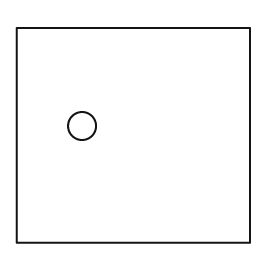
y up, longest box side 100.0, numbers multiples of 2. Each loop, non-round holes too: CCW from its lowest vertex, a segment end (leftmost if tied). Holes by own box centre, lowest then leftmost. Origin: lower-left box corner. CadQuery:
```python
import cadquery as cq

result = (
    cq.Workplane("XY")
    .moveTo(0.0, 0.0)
    .lineTo(100.0, 0.0)
    .lineTo(100.0, 92.0)
    .lineTo(0.0, 92.0)
    .close()
    .moveTo(28.0, 50.0)
    .circle(6.0)
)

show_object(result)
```